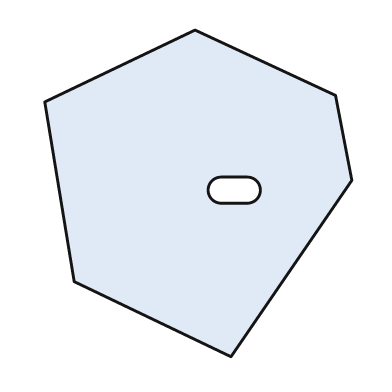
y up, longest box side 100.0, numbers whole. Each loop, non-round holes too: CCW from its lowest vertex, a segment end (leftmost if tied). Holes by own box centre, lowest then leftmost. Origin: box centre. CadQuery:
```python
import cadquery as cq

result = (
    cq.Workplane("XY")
    .moveTo(10.0, -50.0)
    .lineTo(47.0, 4.0)
    .lineTo(42.0, 30.0)
    .lineTo(-1.0, 50.0)
    .lineTo(-47.0, 28.0)
    .lineTo(-38.0, -27.0)
    .close()
    .moveTo(7.0, -3.0)
    .lineTo(15.0, -3.0)
    .threePointArc((19.0, 1.0), (15.0, 5.0))
    .lineTo(7.0, 5.0)
    .threePointArc((3.0, 1.0), (7.0, -3.0))
    .close()
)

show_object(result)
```